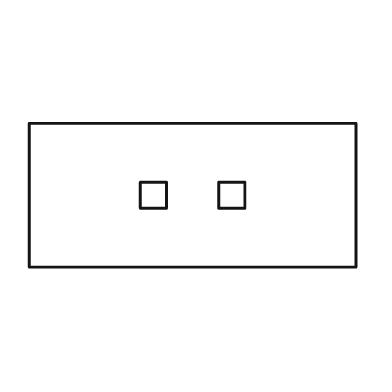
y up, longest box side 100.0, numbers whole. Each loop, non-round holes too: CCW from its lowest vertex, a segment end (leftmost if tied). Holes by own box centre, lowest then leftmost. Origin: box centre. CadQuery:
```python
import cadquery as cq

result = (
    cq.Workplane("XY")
    .moveTo(-50.0, -22.0)
    .lineTo(50.0, -22.0)
    .lineTo(50.0, 22.0)
    .lineTo(-50.0, 22.0)
    .close()
    .moveTo(-16.0, -4.0)
    .lineTo(-8.0, -4.0)
    .lineTo(-8.0, 4.0)
    .lineTo(-16.0, 4.0)
    .close()
    .moveTo(8.0, -4.0)
    .lineTo(16.0, -4.0)
    .lineTo(16.0, 4.0)
    .lineTo(8.0, 4.0)
    .close()
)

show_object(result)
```